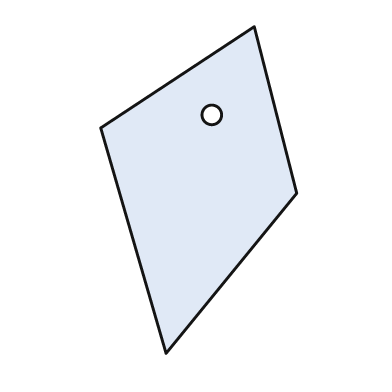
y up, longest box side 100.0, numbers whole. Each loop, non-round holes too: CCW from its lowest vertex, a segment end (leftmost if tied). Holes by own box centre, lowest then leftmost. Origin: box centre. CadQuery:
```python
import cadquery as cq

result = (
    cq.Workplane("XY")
    .moveTo(-10.0, -50.0)
    .lineTo(30.0, -1.0)
    .lineTo(17.0, 50.0)
    .lineTo(-30.0, 19.0)
    .close()
    .moveTo(4.0, 23.0)
    .circle(3.0)
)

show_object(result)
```